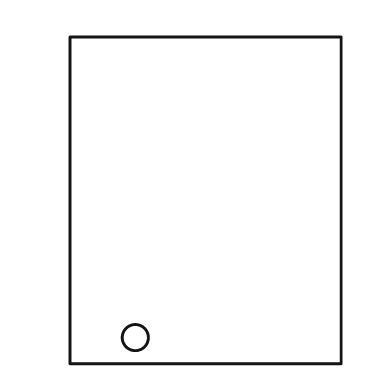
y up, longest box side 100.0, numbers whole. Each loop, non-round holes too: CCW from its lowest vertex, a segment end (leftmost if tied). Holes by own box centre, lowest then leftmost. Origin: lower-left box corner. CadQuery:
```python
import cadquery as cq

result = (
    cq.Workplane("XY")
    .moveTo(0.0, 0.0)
    .lineTo(83.0, 0.0)
    .lineTo(83.0, 100.0)
    .lineTo(0.0, 100.0)
    .close()
    .moveTo(20.0, 8.0)
    .circle(4.0)
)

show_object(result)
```